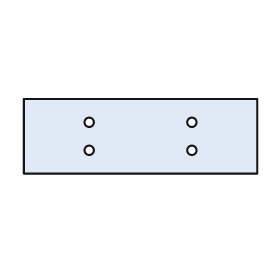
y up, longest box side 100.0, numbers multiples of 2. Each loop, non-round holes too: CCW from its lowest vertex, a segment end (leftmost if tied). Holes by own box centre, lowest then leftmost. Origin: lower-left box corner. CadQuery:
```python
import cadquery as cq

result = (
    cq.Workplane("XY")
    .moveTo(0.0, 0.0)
    .lineTo(100.0, 0.0)
    .lineTo(100.0, 32.0)
    .lineTo(0.0, 32.0)
    .close()
    .moveTo(28.0, 10.0)
    .circle(2.0)
    .moveTo(72.0, 10.0)
    .circle(2.0)
    .moveTo(28.0, 22.0)
    .circle(2.0)
    .moveTo(72.0, 22.0)
    .circle(2.0)
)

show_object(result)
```